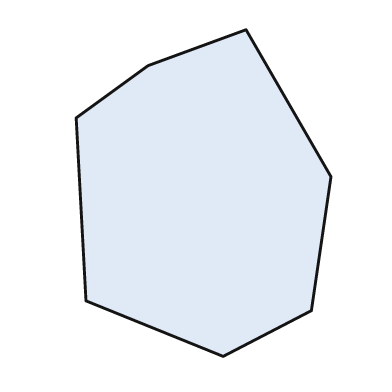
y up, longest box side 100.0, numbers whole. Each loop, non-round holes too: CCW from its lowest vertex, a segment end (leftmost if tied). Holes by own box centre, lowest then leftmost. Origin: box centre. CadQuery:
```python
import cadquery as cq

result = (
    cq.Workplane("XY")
    .moveTo(6.0, -50.0)
    .lineTo(33.0, -36.0)
    .lineTo(39.0, 5.0)
    .lineTo(13.0, 50.0)
    .lineTo(-17.0, 39.0)
    .lineTo(-39.0, 23.0)
    .lineTo(-36.0, -33.0)
    .close()
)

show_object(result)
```